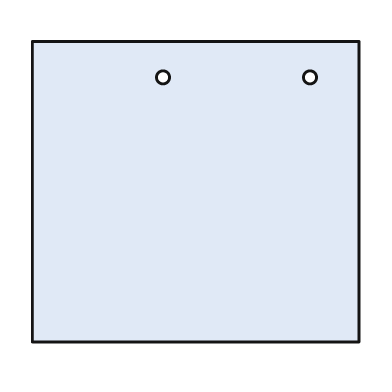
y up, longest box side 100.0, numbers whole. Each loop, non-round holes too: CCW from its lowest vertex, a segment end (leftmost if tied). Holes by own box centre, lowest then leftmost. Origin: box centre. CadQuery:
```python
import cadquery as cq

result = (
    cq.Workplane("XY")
    .moveTo(-50.0, -46.0)
    .lineTo(50.0, -46.0)
    .lineTo(50.0, 46.0)
    .lineTo(-50.0, 46.0)
    .close()
    .moveTo(-10.0, 35.0)
    .circle(2.0)
    .moveTo(35.0, 35.0)
    .circle(2.0)
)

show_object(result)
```